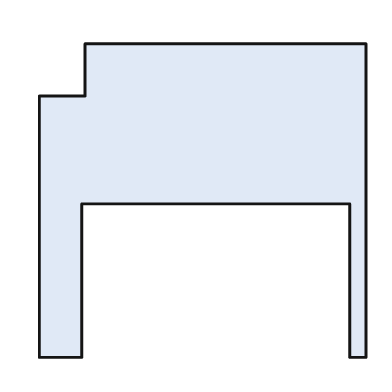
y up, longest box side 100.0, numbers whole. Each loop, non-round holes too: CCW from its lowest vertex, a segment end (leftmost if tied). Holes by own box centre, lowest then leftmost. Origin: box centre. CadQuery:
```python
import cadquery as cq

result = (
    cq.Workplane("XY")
    .moveTo(-50.0, -48.0)
    .lineTo(-37.0, -48.0)
    .lineTo(-37.0, -1.0)
    .lineTo(45.0, -1.0)
    .lineTo(45.0, -48.0)
    .lineTo(50.0, -48.0)
    .lineTo(50.0, 48.0)
    .lineTo(-36.0, 48.0)
    .lineTo(-36.0, 32.0)
    .lineTo(-50.0, 32.0)
    .close()
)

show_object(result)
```